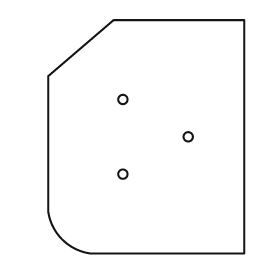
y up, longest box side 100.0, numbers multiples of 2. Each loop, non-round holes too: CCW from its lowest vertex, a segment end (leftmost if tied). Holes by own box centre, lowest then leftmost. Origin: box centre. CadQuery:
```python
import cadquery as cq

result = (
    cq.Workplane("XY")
    .moveTo(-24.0, -50.0)
    .lineTo(42.0, -50.0)
    .lineTo(42.0, 50.0)
    .lineTo(-14.0, 50.0)
    .lineTo(-42.0, 26.0)
    .lineTo(-42.0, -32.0)
    .threePointArc((-36.0, -44.0), (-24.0, -50.0))
    .close()
    .moveTo(-10.0, -16.0)
    .circle(2.0)
    .moveTo(18.0, 0.0)
    .circle(2.0)
    .moveTo(-10.0, 16.0)
    .circle(2.0)
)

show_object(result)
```